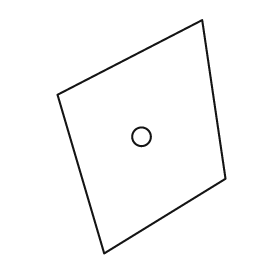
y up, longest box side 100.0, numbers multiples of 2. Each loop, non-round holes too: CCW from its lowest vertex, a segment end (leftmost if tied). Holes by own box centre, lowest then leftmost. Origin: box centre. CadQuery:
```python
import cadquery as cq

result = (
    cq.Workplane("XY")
    .moveTo(-16.0, -50.0)
    .lineTo(36.0, -18.0)
    .lineTo(26.0, 50.0)
    .lineTo(-36.0, 18.0)
    .close()
    .moveTo(0.0, 0.0)
    .circle(4.0)
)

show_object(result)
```